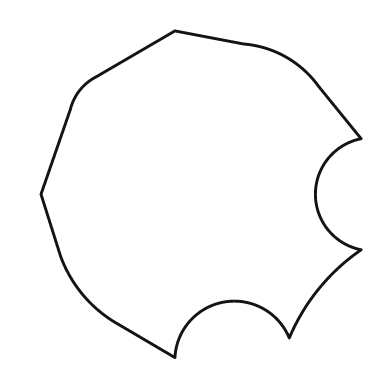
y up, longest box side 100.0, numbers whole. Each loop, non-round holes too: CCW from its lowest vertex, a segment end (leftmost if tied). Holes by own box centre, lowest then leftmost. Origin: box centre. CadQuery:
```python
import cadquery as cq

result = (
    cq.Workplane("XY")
    .moveTo(-8.0, -50.0)
    .threePointArc((7.0, -33.0), (27.0, -44.0))
    .threePointArc((36.0, -29.0), (49.0, -17.0))
    .threePointArc((35.0, 0.0), (49.0, 17.0))
    .lineTo(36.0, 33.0)
    .threePointArc((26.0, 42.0), (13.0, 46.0))
    .lineTo(-8.0, 50.0)
    .lineTo(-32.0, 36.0)
    .threePointArc((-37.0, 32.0), (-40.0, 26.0))
    .lineTo(-49.0, 0.0)
    .lineTo(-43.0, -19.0)
    .threePointArc((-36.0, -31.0), (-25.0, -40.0))
    .close()
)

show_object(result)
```